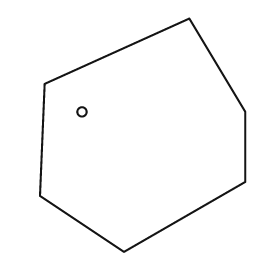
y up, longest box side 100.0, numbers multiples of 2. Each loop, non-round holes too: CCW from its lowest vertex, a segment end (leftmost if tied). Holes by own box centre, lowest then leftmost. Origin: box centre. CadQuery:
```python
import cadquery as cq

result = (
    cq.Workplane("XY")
    .moveTo(-8.0, -50.0)
    .lineTo(44.0, -20.0)
    .lineTo(44.0, 10.0)
    .lineTo(20.0, 50.0)
    .lineTo(-42.0, 22.0)
    .lineTo(-44.0, -26.0)
    .close()
    .moveTo(-26.0, 10.0)
    .circle(2.0)
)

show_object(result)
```